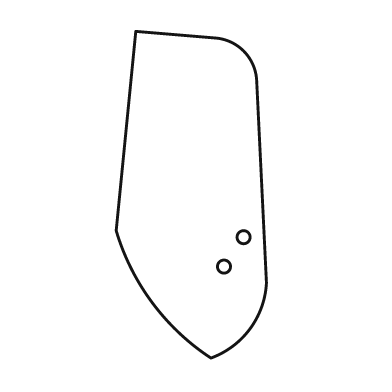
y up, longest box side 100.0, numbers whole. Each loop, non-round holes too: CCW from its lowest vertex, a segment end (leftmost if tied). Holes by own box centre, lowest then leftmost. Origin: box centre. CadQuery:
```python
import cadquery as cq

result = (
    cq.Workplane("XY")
    .moveTo(6.0, -50.0)
    .threePointArc((18.0, -41.0), (23.0, -27.0))
    .lineTo(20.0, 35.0)
    .threePointArc((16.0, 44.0), (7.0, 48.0))
    .lineTo(-17.0, 50.0)
    .lineTo(-23.0, -11.0)
    .threePointArc((-12.0, -33.0), (6.0, -50.0))
    .close()
    .moveTo(10.0, -22.0)
    .circle(2.0)
    .moveTo(16.0, -13.0)
    .circle(2.0)
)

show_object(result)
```